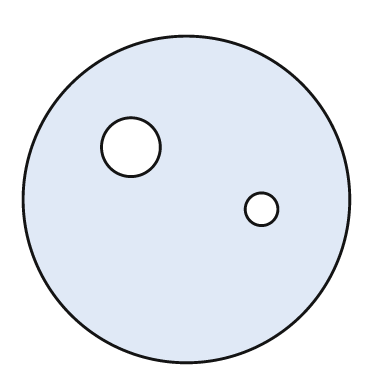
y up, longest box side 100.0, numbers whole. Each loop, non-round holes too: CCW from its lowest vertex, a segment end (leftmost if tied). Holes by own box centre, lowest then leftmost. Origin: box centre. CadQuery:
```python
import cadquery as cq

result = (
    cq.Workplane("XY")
    .moveTo(0.0, 0.0)
    .circle(50.0)
    .moveTo(23.0, -3.0)
    .circle(5.0)
    .moveTo(-17.0, 16.0)
    .circle(9.0)
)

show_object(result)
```